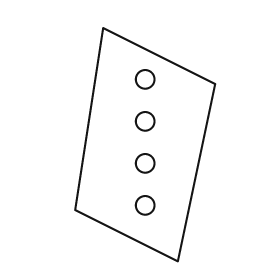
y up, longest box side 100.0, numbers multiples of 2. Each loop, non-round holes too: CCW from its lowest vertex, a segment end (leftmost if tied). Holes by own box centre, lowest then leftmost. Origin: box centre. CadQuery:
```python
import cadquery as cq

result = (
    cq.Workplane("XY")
    .moveTo(14.0, -50.0)
    .lineTo(30.0, 26.0)
    .lineTo(-18.0, 50.0)
    .lineTo(-30.0, -28.0)
    .close()
    .moveTo(0.0, -26.0)
    .circle(4.0)
    .moveTo(0.0, -8.0)
    .circle(4.0)
    .moveTo(0.0, 10.0)
    .circle(4.0)
    .moveTo(0.0, 28.0)
    .circle(4.0)
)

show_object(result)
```